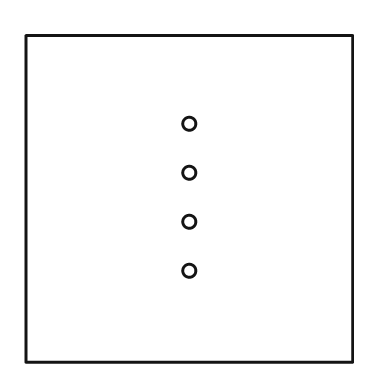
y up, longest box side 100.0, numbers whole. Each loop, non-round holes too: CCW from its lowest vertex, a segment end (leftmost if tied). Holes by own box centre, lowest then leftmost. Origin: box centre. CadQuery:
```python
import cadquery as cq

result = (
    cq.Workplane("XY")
    .moveTo(-50.0, -50.0)
    .lineTo(50.0, -50.0)
    .lineTo(50.0, 50.0)
    .lineTo(-50.0, 50.0)
    .close()
    .moveTo(0.0, -22.0)
    .circle(2.0)
    .moveTo(0.0, -7.0)
    .circle(2.0)
    .moveTo(0.0, 8.0)
    .circle(2.0)
    .moveTo(0.0, 23.0)
    .circle(2.0)
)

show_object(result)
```